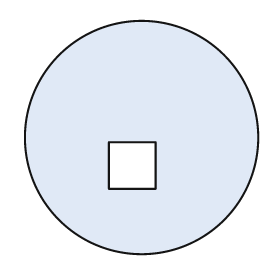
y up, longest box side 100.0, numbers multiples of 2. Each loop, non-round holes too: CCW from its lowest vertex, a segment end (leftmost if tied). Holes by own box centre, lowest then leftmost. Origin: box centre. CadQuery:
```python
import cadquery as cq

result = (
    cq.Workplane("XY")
    .moveTo(0.0, 0.0)
    .circle(50.0)
    .moveTo(-14.0, -22.0)
    .lineTo(6.0, -22.0)
    .lineTo(6.0, -2.0)
    .lineTo(-14.0, -2.0)
    .close()
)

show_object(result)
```